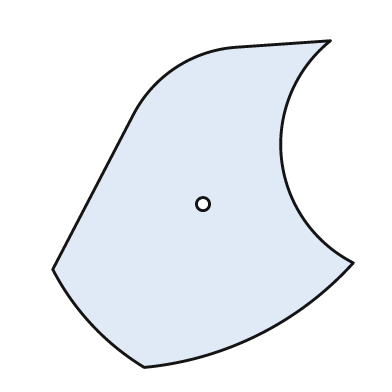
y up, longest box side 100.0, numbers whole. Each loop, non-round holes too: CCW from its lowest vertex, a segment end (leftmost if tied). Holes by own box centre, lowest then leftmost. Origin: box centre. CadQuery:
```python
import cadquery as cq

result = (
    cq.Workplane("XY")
    .moveTo(-18.0, -50.0)
    .threePointArc((17.0, -40.0), (46.0, -18.0))
    .threePointArc((24.0, 14.0), (39.0, 50.0))
    .lineTo(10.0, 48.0)
    .threePointArc((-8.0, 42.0), (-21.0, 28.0))
    .lineTo(-46.0, -20.0)
    .threePointArc((-34.0, -37.0), (-18.0, -50.0))
    .close()
    .moveTo(0.0, 0.0)
    .circle(2.0)
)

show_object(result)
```